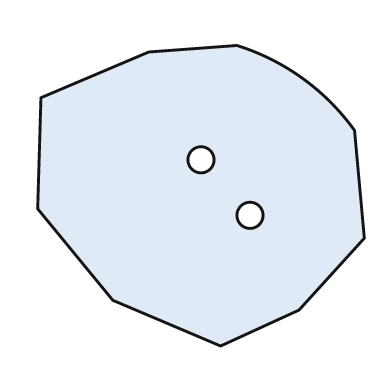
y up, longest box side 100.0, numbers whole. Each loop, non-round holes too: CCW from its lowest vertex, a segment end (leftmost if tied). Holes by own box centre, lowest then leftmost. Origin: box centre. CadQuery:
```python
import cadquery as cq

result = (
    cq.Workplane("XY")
    .moveTo(6.0, -46.0)
    .lineTo(30.0, -35.0)
    .lineTo(50.0, -13.0)
    .lineTo(47.0, 20.0)
    .threePointArc((31.0, 36.0), (11.0, 46.0))
    .lineTo(-16.0, 44.0)
    .lineTo(-49.0, 30.0)
    .lineTo(-50.0, -4.0)
    .lineTo(-27.0, -32.0)
    .close()
    .moveTo(15.0, -6.0)
    .circle(4.0)
    .moveTo(0.0, 11.0)
    .circle(4.0)
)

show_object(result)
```